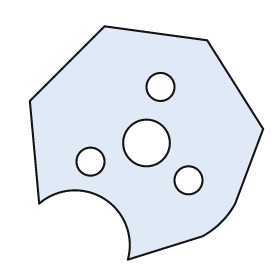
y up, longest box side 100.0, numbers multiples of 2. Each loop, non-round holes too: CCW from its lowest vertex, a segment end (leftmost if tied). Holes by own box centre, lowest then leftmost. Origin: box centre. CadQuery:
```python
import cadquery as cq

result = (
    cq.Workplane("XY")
    .moveTo(-8.0, -50.0)
    .lineTo(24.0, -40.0)
    .threePointArc((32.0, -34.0), (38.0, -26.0))
    .lineTo(50.0, 6.0)
    .lineTo(26.0, 44.0)
    .lineTo(-18.0, 50.0)
    .lineTo(-50.0, 18.0)
    .lineTo(-46.0, -26.0)
    .threePointArc((-18.0, -24.0), (-8.0, -50.0))
    .close()
    .moveTo(18.0, -16.0)
    .circle(6.0)
    .moveTo(-24.0, -8.0)
    .circle(6.0)
    .moveTo(0.0, 0.0)
    .circle(10.0)
    .moveTo(6.0, 24.0)
    .circle(6.0)
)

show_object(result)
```